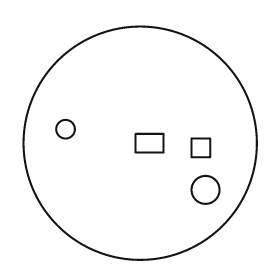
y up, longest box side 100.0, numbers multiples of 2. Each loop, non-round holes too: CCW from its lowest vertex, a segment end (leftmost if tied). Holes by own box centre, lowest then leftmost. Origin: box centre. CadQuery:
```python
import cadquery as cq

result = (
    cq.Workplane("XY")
    .moveTo(0.0, 0.0)
    .circle(50.0)
    .moveTo(28.0, -20.0)
    .circle(6.0)
    .moveTo(22.0, -6.0)
    .lineTo(30.0, -6.0)
    .lineTo(30.0, 2.0)
    .lineTo(22.0, 2.0)
    .close()
    .moveTo(-2.0, -4.0)
    .lineTo(10.0, -4.0)
    .lineTo(10.0, 4.0)
    .lineTo(-2.0, 4.0)
    .close()
    .moveTo(-32.0, 6.0)
    .circle(4.0)
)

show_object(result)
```